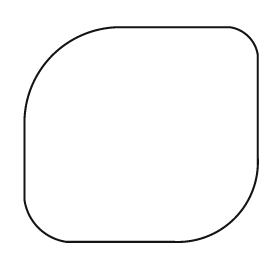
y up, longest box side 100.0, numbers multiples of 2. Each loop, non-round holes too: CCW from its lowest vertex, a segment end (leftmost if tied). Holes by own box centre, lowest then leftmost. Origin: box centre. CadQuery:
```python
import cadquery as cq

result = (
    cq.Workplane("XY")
    .moveTo(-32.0, -46.0)
    .lineTo(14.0, -46.0)
    .threePointArc((40.0, -36.0), (50.0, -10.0))
    .lineTo(50.0, 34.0)
    .threePointArc((46.0, 42.0), (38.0, 46.0))
    .lineTo(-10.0, 46.0)
    .threePointArc((-38.0, 34.0), (-50.0, 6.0))
    .lineTo(-50.0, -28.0)
    .threePointArc((-44.0, -40.0), (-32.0, -46.0))
    .close()
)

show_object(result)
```